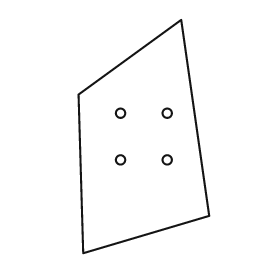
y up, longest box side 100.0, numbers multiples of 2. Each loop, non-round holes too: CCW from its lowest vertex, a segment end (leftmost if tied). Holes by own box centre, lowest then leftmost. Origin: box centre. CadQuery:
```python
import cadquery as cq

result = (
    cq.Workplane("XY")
    .moveTo(-26.0, -50.0)
    .lineTo(28.0, -34.0)
    .lineTo(16.0, 50.0)
    .lineTo(-28.0, 18.0)
    .close()
    .moveTo(-10.0, -10.0)
    .circle(2.0)
    .moveTo(10.0, -10.0)
    .circle(2.0)
    .moveTo(-10.0, 10.0)
    .circle(2.0)
    .moveTo(10.0, 10.0)
    .circle(2.0)
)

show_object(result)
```